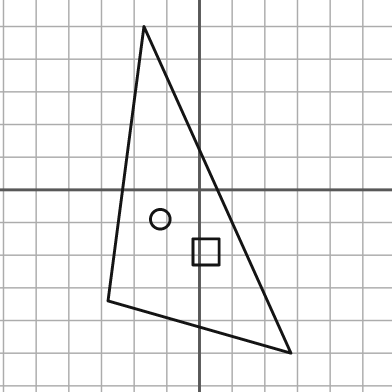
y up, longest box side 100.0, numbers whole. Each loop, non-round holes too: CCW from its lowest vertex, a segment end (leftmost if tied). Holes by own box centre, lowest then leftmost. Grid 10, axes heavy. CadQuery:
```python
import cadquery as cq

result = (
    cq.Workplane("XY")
    .moveTo(28.0, -50.0)
    .lineTo(-17.0, 50.0)
    .lineTo(-28.0, -34.0)
    .close()
    .moveTo(-2.0, -23.0)
    .lineTo(6.0, -23.0)
    .lineTo(6.0, -15.0)
    .lineTo(-2.0, -15.0)
    .close()
    .moveTo(-12.0, -9.0)
    .circle(3.0)
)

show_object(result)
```